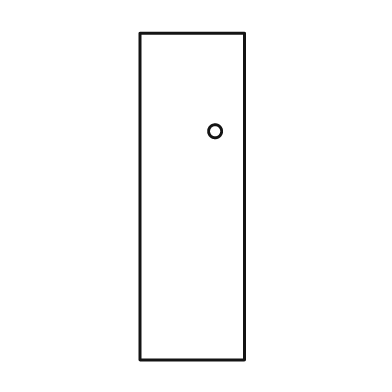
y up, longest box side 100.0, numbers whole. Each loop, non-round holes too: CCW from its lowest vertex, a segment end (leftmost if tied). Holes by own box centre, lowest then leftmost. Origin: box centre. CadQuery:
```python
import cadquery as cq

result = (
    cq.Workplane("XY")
    .moveTo(-16.0, -50.0)
    .lineTo(16.0, -50.0)
    .lineTo(16.0, 50.0)
    .lineTo(-16.0, 50.0)
    .close()
    .moveTo(7.0, 20.0)
    .circle(2.0)
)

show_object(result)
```